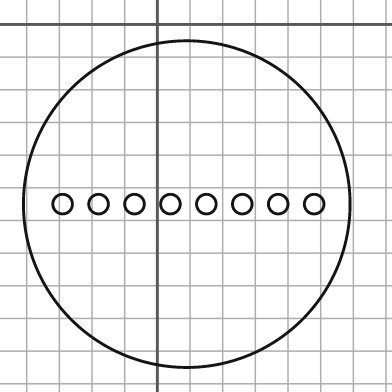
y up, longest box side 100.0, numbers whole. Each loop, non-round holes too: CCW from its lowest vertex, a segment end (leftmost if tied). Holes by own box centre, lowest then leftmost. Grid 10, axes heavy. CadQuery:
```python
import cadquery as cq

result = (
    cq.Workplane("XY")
    .moveTo(9.0, -55.0)
    .circle(50.0)
    .moveTo(-29.0, -55.0)
    .circle(3.0)
    .moveTo(-18.0, -55.0)
    .circle(3.0)
    .moveTo(-7.0, -55.0)
    .circle(3.0)
    .moveTo(4.0, -55.0)
    .circle(3.0)
    .moveTo(15.0, -55.0)
    .circle(3.0)
    .moveTo(26.0, -55.0)
    .circle(3.0)
    .moveTo(37.0, -55.0)
    .circle(3.0)
    .moveTo(48.0, -55.0)
    .circle(3.0)
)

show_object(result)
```